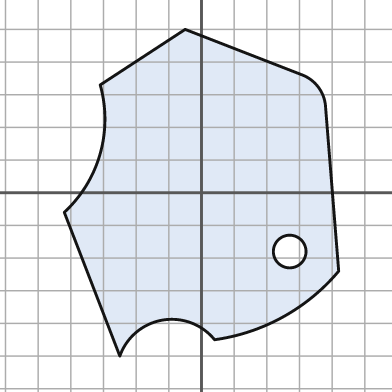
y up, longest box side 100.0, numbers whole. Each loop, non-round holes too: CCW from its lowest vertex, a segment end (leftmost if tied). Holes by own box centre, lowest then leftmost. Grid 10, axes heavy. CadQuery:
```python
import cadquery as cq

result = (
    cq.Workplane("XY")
    .moveTo(-25.0, -50.0)
    .threePointArc((-12.0, -39.0), (4.0, -45.0))
    .threePointArc((25.0, -38.0), (42.0, -24.0))
    .lineTo(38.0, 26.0)
    .threePointArc((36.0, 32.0), (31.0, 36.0))
    .lineTo(-5.0, 50.0)
    .lineTo(-31.0, 33.0)
    .threePointArc((-31.0, 12.0), (-42.0, -6.0))
    .close()
    .moveTo(27.0, -18.0)
    .circle(5.0)
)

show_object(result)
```